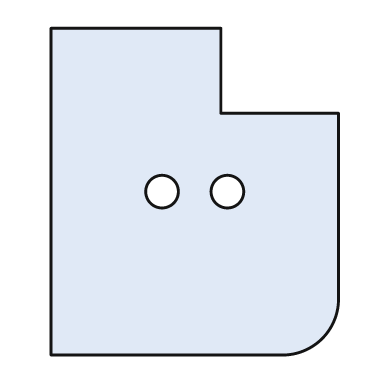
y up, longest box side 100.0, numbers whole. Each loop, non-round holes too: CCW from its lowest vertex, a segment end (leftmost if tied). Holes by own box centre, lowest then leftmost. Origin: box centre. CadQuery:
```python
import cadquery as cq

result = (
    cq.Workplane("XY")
    .moveTo(-44.0, -50.0)
    .lineTo(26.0, -50.0)
    .threePointArc((39.0, -45.0), (44.0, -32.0))
    .lineTo(44.0, 24.0)
    .lineTo(8.0, 24.0)
    .lineTo(8.0, 50.0)
    .lineTo(-44.0, 50.0)
    .close()
    .moveTo(-10.0, 0.0)
    .circle(5.0)
    .moveTo(10.0, 0.0)
    .circle(5.0)
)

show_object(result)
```